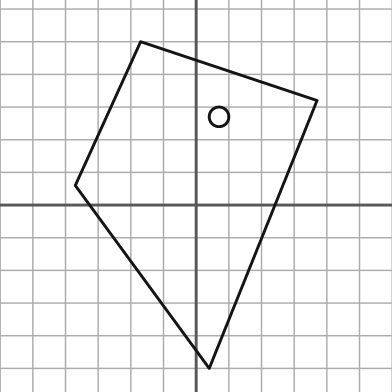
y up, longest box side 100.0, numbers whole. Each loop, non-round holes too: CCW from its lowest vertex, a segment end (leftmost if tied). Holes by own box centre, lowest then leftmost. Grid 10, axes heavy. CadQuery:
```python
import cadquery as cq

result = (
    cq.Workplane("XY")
    .moveTo(4.0, -50.0)
    .lineTo(37.0, 32.0)
    .lineTo(-17.0, 50.0)
    .lineTo(-37.0, 6.0)
    .close()
    .moveTo(7.0, 27.0)
    .circle(3.0)
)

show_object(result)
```